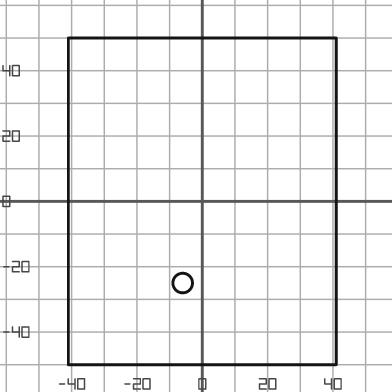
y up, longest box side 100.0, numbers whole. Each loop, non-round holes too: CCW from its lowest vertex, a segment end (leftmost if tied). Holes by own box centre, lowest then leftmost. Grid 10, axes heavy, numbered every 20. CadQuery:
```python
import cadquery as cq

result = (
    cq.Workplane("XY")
    .moveTo(-41.0, -50.0)
    .lineTo(41.0, -50.0)
    .lineTo(41.0, 50.0)
    .lineTo(-41.0, 50.0)
    .close()
    .moveTo(-6.0, -25.0)
    .circle(3.0)
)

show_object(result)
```